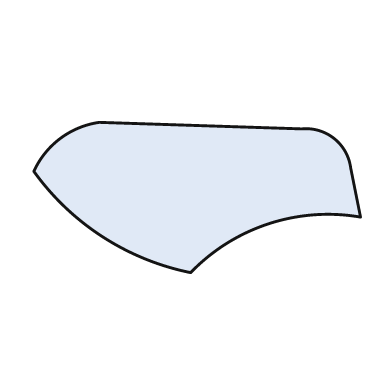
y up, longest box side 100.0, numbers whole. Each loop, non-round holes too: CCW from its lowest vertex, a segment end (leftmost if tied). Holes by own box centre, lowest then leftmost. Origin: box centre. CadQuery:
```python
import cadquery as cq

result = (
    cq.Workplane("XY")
    .moveTo(-2.0, -23.0)
    .threePointArc((22.0, -8.0), (50.0, -6.0))
    .lineTo(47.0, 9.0)
    .threePointArc((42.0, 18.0), (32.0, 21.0))
    .lineTo(-30.0, 23.0)
    .threePointArc((-42.0, 18.0), (-50.0, 8.0))
    .threePointArc((-29.0, -12.0), (-2.0, -23.0))
    .close()
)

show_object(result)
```